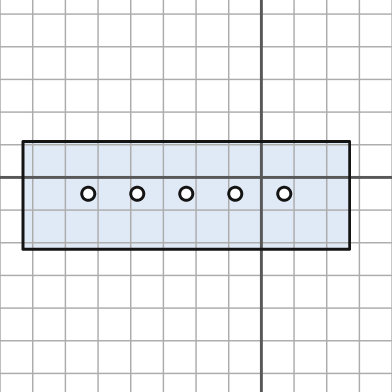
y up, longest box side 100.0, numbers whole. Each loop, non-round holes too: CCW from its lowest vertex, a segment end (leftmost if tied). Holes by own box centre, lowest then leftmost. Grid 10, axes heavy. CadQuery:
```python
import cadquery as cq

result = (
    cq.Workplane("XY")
    .moveTo(-73.0, -22.0)
    .lineTo(27.0, -22.0)
    .lineTo(27.0, 11.0)
    .lineTo(-73.0, 11.0)
    .close()
    .moveTo(-53.0, -5.0)
    .circle(2.0)
    .moveTo(-38.0, -5.0)
    .circle(2.0)
    .moveTo(-23.0, -5.0)
    .circle(2.0)
    .moveTo(-8.0, -5.0)
    .circle(2.0)
    .moveTo(7.0, -5.0)
    .circle(2.0)
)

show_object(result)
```